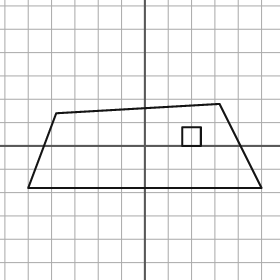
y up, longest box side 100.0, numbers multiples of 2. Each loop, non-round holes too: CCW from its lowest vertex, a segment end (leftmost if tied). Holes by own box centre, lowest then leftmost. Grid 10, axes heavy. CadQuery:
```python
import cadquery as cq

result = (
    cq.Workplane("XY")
    .moveTo(-50.0, -18.0)
    .lineTo(50.0, -18.0)
    .lineTo(32.0, 18.0)
    .lineTo(-38.0, 14.0)
    .close()
    .moveTo(16.0, 0.0)
    .lineTo(24.0, 0.0)
    .lineTo(24.0, 8.0)
    .lineTo(16.0, 8.0)
    .close()
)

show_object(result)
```